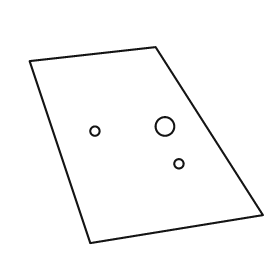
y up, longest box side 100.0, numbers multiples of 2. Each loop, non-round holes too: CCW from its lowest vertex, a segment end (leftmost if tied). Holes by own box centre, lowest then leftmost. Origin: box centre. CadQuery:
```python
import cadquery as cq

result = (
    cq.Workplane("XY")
    .moveTo(-24.0, -42.0)
    .lineTo(50.0, -30.0)
    .lineTo(4.0, 42.0)
    .lineTo(-50.0, 36.0)
    .close()
    .moveTo(14.0, -8.0)
    .circle(2.0)
    .moveTo(-22.0, 6.0)
    .circle(2.0)
    .moveTo(8.0, 8.0)
    .circle(4.0)
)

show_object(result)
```